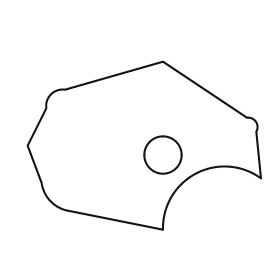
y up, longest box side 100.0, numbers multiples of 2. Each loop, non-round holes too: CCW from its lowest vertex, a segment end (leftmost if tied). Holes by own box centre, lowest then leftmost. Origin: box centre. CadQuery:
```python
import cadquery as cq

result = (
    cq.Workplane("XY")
    .moveTo(8.0, -36.0)
    .threePointArc((22.0, -12.0), (50.0, -14.0))
    .lineTo(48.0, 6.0)
    .threePointArc((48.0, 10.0), (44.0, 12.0))
    .lineTo(8.0, 36.0)
    .lineTo(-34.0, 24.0)
    .threePointArc((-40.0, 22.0), (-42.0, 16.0))
    .lineTo(-50.0, 0.0)
    .lineTo(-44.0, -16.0)
    .threePointArc((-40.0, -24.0), (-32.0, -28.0))
    .close()
    .moveTo(8.0, -4.0)
    .circle(8.0)
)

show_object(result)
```